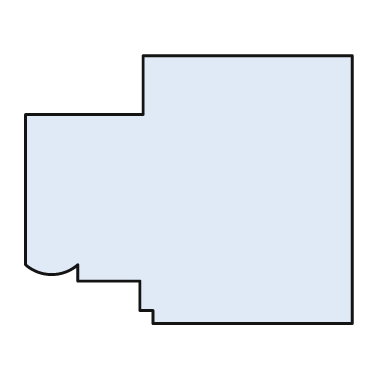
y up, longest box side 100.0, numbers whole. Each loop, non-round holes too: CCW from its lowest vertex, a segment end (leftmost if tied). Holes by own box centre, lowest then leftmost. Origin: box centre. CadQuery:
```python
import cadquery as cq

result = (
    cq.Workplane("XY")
    .moveTo(-11.0, -41.0)
    .lineTo(50.0, -41.0)
    .lineTo(50.0, 41.0)
    .lineTo(-14.0, 41.0)
    .lineTo(-14.0, 23.0)
    .lineTo(-50.0, 23.0)
    .lineTo(-50.0, -23.0)
    .threePointArc((-42.0, -26.0), (-34.0, -23.0))
    .lineTo(-34.0, -28.0)
    .lineTo(-15.0, -28.0)
    .lineTo(-15.0, -37.0)
    .lineTo(-11.0, -37.0)
    .close()
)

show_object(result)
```